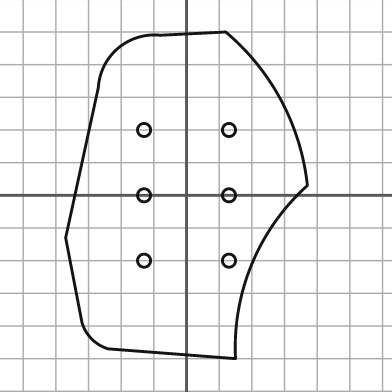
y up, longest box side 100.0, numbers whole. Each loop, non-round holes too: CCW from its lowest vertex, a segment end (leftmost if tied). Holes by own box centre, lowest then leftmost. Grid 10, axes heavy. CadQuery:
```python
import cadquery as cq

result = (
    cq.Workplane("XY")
    .moveTo(15.0, -50.0)
    .threePointArc((20.0, -21.0), (37.0, 3.0))
    .threePointArc((29.0, 29.0), (12.0, 50.0))
    .lineTo(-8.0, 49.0)
    .threePointArc((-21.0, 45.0), (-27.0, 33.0))
    .lineTo(-37.0, -13.0)
    .lineTo(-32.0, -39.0)
    .threePointArc((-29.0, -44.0), (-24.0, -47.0))
    .close()
    .moveTo(-13.0, -20.0)
    .circle(2.0)
    .moveTo(13.0, -20.0)
    .circle(2.0)
    .moveTo(-13.0, 0.0)
    .circle(2.0)
    .moveTo(13.0, 0.0)
    .circle(2.0)
    .moveTo(-13.0, 20.0)
    .circle(2.0)
    .moveTo(13.0, 20.0)
    .circle(2.0)
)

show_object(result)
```